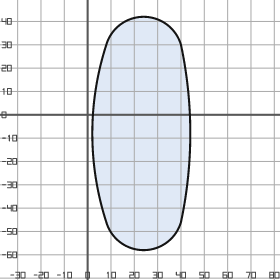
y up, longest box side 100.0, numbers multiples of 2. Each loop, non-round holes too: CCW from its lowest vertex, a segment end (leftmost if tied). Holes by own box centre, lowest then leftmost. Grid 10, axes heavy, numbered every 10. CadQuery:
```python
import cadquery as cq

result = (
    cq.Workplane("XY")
    .moveTo(8.0, -46.0)
    .threePointArc((24.0, -58.0), (40.0, -46.0))
    .threePointArc((44.0, -8.0), (40.0, 30.0))
    .threePointArc((24.0, 42.0), (8.0, 30.0))
    .threePointArc((2.0, -8.0), (8.0, -46.0))
    .close()
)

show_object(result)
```